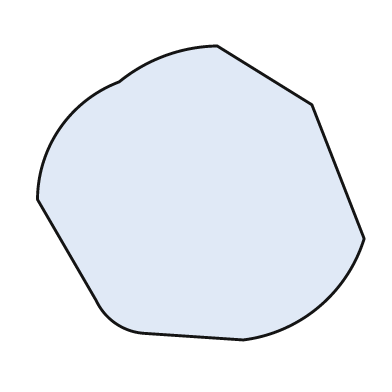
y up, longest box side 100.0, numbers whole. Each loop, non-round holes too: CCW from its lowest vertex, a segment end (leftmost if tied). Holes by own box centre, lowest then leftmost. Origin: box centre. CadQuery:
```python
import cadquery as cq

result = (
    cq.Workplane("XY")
    .moveTo(13.0, -45.0)
    .threePointArc((36.0, -35.0), (50.0, -14.0))
    .lineTo(34.0, 27.0)
    .lineTo(5.0, 45.0)
    .threePointArc((-11.0, 42.0), (-25.0, 34.0))
    .threePointArc((-43.0, 20.0), (-50.0, -2.0))
    .lineTo(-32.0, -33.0)
    .threePointArc((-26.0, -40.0), (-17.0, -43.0))
    .close()
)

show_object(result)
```